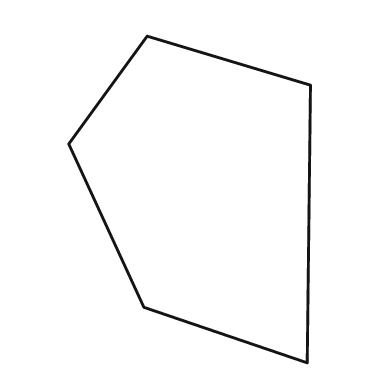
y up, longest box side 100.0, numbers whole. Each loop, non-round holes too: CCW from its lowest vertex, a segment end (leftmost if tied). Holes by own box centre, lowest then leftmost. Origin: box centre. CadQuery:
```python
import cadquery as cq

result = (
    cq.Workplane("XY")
    .moveTo(36.0, -50.0)
    .lineTo(37.0, 35.0)
    .lineTo(-13.0, 50.0)
    .lineTo(-37.0, 17.0)
    .lineTo(-14.0, -33.0)
    .close()
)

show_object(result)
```